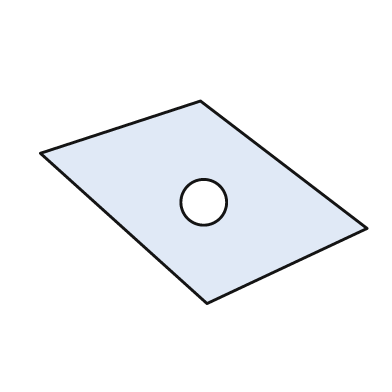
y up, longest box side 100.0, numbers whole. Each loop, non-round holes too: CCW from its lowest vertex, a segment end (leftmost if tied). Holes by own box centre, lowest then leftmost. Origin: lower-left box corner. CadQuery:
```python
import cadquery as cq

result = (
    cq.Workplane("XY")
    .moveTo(51.0, 0.0)
    .lineTo(100.0, 23.0)
    .lineTo(49.0, 62.0)
    .lineTo(0.0, 46.0)
    .close()
    .moveTo(50.0, 31.0)
    .circle(7.0)
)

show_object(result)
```